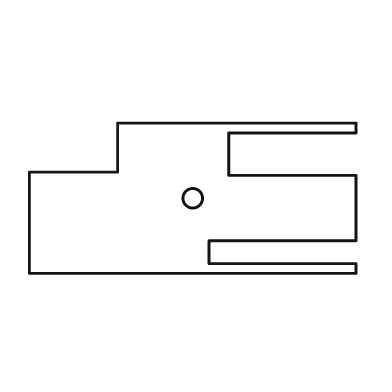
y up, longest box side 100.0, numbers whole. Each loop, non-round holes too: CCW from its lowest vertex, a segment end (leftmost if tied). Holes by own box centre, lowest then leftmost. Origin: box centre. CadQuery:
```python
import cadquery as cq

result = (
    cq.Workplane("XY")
    .moveTo(-50.0, -23.0)
    .lineTo(50.0, -23.0)
    .lineTo(50.0, -20.0)
    .lineTo(5.0, -20.0)
    .lineTo(5.0, -13.0)
    .lineTo(50.0, -13.0)
    .lineTo(50.0, 7.0)
    .lineTo(11.0, 7.0)
    .lineTo(11.0, 20.0)
    .lineTo(50.0, 20.0)
    .lineTo(50.0, 23.0)
    .lineTo(-23.0, 23.0)
    .lineTo(-23.0, 8.0)
    .lineTo(-50.0, 8.0)
    .close()
    .moveTo(0.0, 0.0)
    .circle(3.0)
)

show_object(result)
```